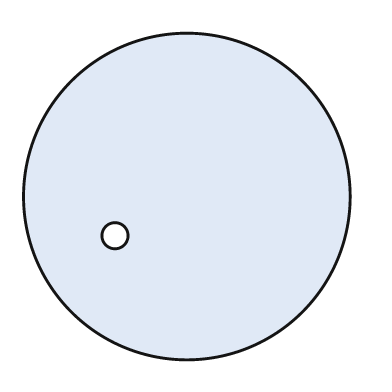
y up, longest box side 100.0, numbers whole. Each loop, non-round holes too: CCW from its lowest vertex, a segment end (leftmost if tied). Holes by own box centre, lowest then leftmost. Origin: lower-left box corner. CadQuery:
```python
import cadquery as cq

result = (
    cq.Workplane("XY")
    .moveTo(50.0, 50.0)
    .circle(50.0)
    .moveTo(28.0, 38.0)
    .circle(4.0)
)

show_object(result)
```